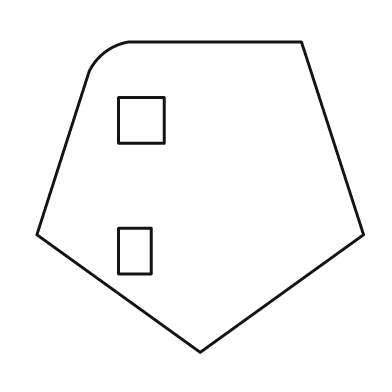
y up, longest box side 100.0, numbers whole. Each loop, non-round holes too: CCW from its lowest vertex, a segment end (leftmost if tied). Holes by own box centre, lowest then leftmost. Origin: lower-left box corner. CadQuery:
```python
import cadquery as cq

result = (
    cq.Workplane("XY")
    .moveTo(50.0, 0.0)
    .lineTo(100.0, 36.0)
    .lineTo(81.0, 95.0)
    .lineTo(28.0, 95.0)
    .threePointArc((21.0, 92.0), (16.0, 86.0))
    .lineTo(0.0, 36.0)
    .close()
    .moveTo(25.0, 24.0)
    .lineTo(35.0, 24.0)
    .lineTo(35.0, 38.0)
    .lineTo(25.0, 38.0)
    .close()
    .moveTo(25.0, 64.0)
    .lineTo(39.0, 64.0)
    .lineTo(39.0, 78.0)
    .lineTo(25.0, 78.0)
    .close()
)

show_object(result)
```